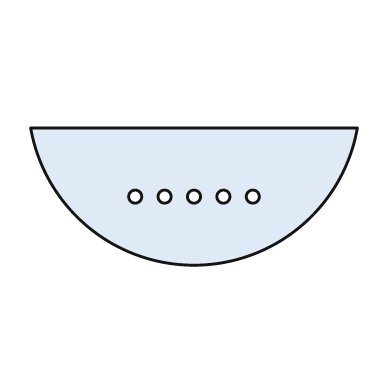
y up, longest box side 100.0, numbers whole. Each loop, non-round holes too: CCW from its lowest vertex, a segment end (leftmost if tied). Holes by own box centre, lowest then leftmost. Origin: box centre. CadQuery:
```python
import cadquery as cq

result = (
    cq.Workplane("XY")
    .moveTo(-50.0, 21.0)
    .threePointArc((0.0, -21.0), (50.0, 21.0))
    .close()
    .moveTo(-18.0, 0.0)
    .circle(2.0)
    .moveTo(-9.0, 0.0)
    .circle(2.0)
    .moveTo(0.0, 0.0)
    .circle(2.0)
    .moveTo(9.0, 0.0)
    .circle(2.0)
    .moveTo(18.0, 0.0)
    .circle(2.0)
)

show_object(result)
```